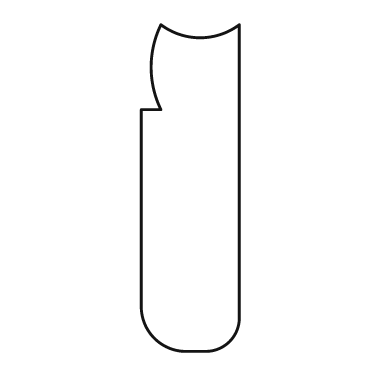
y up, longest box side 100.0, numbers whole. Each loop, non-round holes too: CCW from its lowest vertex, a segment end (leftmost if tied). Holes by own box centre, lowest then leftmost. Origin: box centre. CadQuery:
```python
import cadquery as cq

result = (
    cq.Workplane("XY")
    .moveTo(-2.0, -50.0)
    .lineTo(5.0, -50.0)
    .threePointArc((12.0, -47.0), (15.0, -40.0))
    .lineTo(15.0, 50.0)
    .threePointArc((3.0, 46.0), (-9.0, 50.0))
    .threePointArc((-12.0, 37.0), (-9.0, 24.0))
    .lineTo(-15.0, 24.0)
    .lineTo(-15.0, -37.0)
    .threePointArc((-11.0, -46.0), (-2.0, -50.0))
    .close()
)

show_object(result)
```